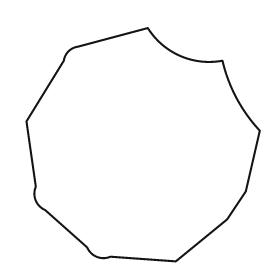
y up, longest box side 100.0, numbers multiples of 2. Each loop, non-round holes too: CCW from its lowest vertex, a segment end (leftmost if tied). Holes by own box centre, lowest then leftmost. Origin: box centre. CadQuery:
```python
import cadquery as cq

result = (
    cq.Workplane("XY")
    .moveTo(14.0, -50.0)
    .lineTo(36.0, -32.0)
    .lineTo(44.0, -20.0)
    .lineTo(50.0, 6.0)
    .threePointArc((40.0, 20.0), (34.0, 36.0))
    .threePointArc((16.0, 38.0), (2.0, 50.0))
    .lineTo(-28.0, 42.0)
    .threePointArc((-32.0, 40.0), (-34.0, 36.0))
    .lineTo(-50.0, 10.0)
    .lineTo(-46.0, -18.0)
    .threePointArc((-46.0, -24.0), (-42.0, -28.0))
    .lineTo(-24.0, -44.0)
    .threePointArc((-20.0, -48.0), (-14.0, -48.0))
    .close()
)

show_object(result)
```